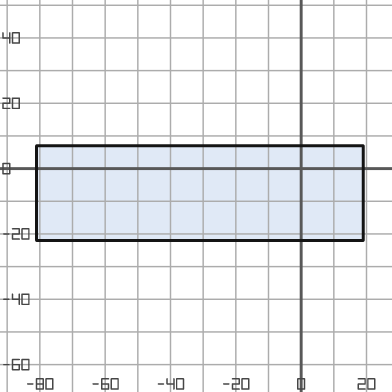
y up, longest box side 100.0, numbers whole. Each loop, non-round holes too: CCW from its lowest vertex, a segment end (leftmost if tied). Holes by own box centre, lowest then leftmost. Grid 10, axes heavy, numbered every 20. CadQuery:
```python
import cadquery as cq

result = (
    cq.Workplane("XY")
    .moveTo(-81.0, -22.0)
    .lineTo(19.0, -22.0)
    .lineTo(19.0, 7.0)
    .lineTo(-81.0, 7.0)
    .close()
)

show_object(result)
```